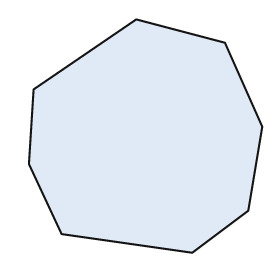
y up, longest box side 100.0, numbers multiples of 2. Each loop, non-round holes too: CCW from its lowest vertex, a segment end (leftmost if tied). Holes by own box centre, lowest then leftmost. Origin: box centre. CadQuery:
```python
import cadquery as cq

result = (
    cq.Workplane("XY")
    .moveTo(20.0, -50.0)
    .lineTo(44.0, -32.0)
    .lineTo(50.0, 4.0)
    .lineTo(34.0, 40.0)
    .lineTo(-4.0, 50.0)
    .lineTo(-48.0, 20.0)
    .lineTo(-50.0, -12.0)
    .lineTo(-36.0, -42.0)
    .close()
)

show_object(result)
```